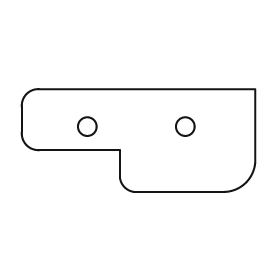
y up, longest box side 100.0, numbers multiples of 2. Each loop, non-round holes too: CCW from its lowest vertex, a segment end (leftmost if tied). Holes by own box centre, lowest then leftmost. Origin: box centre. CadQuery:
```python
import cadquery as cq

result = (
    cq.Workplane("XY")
    .moveTo(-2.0, -22.0)
    .lineTo(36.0, -22.0)
    .threePointArc((46.0, -18.0), (50.0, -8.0))
    .lineTo(50.0, 22.0)
    .lineTo(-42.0, 22.0)
    .threePointArc((-48.0, 20.0), (-50.0, 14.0))
    .lineTo(-50.0, 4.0)
    .threePointArc((-48.0, -2.0), (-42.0, -4.0))
    .lineTo(-8.0, -4.0)
    .lineTo(-8.0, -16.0)
    .threePointArc((-6.0, -20.0), (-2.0, -22.0))
    .close()
    .moveTo(-22.0, 6.0)
    .circle(4.0)
    .moveTo(20.0, 6.0)
    .circle(4.0)
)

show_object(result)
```